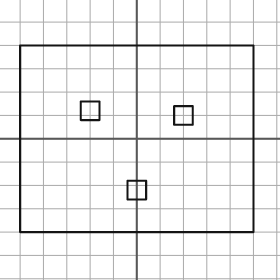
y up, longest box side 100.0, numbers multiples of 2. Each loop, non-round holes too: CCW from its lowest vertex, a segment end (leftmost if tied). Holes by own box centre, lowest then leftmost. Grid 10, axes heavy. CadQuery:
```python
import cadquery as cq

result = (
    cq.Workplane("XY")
    .moveTo(-50.0, -40.0)
    .lineTo(50.0, -40.0)
    .lineTo(50.0, 40.0)
    .lineTo(-50.0, 40.0)
    .close()
    .moveTo(-4.0, -26.0)
    .lineTo(4.0, -26.0)
    .lineTo(4.0, -18.0)
    .lineTo(-4.0, -18.0)
    .close()
    .moveTo(16.0, 6.0)
    .lineTo(24.0, 6.0)
    .lineTo(24.0, 14.0)
    .lineTo(16.0, 14.0)
    .close()
    .moveTo(-24.0, 8.0)
    .lineTo(-16.0, 8.0)
    .lineTo(-16.0, 16.0)
    .lineTo(-24.0, 16.0)
    .close()
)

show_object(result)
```